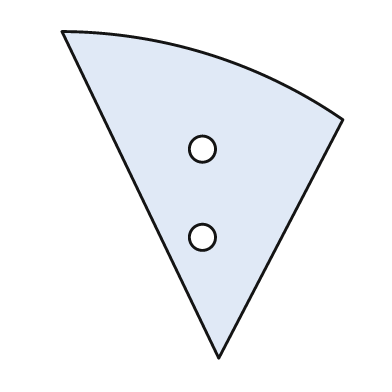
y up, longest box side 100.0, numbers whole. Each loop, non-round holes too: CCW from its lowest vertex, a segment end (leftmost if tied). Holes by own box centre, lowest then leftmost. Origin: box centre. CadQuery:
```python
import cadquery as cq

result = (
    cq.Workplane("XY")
    .moveTo(5.0, -50.0)
    .lineTo(43.0, 23.0)
    .threePointArc((2.0, 43.0), (-43.0, 50.0))
    .close()
    .moveTo(0.0, -13.0)
    .circle(4.0)
    .moveTo(0.0, 14.0)
    .circle(4.0)
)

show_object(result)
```